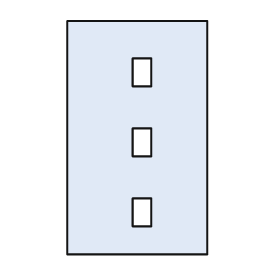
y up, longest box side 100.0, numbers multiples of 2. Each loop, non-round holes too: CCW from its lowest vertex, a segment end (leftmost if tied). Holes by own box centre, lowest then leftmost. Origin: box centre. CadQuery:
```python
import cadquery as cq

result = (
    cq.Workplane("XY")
    .moveTo(-30.0, -50.0)
    .lineTo(30.0, -50.0)
    .lineTo(30.0, 50.0)
    .lineTo(-30.0, 50.0)
    .close()
    .moveTo(-2.0, -38.0)
    .lineTo(6.0, -38.0)
    .lineTo(6.0, -26.0)
    .lineTo(-2.0, -26.0)
    .close()
    .moveTo(-2.0, -8.0)
    .lineTo(6.0, -8.0)
    .lineTo(6.0, 4.0)
    .lineTo(-2.0, 4.0)
    .close()
    .moveTo(-2.0, 22.0)
    .lineTo(6.0, 22.0)
    .lineTo(6.0, 34.0)
    .lineTo(-2.0, 34.0)
    .close()
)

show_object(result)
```